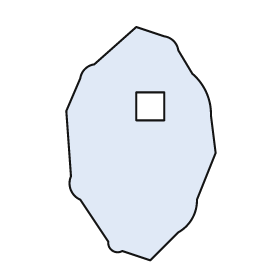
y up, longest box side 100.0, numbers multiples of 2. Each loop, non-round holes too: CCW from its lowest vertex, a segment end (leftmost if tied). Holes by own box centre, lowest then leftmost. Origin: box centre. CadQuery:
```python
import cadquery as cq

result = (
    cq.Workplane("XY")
    .moveTo(4.0, -50.0)
    .lineTo(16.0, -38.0)
    .threePointArc((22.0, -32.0), (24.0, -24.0))
    .lineTo(32.0, -4.0)
    .lineTo(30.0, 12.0)
    .threePointArc((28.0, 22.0), (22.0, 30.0))
    .lineTo(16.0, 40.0)
    .threePointArc((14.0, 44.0), (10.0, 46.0))
    .lineTo(-2.0, 50.0)
    .lineTo(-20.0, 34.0)
    .threePointArc((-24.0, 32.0), (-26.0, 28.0))
    .lineTo(-32.0, 14.0)
    .lineTo(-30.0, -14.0)
    .threePointArc((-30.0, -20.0), (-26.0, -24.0))
    .lineTo(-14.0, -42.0)
    .threePointArc((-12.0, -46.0), (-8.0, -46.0))
    .close()
    .moveTo(-2.0, 10.0)
    .lineTo(10.0, 10.0)
    .lineTo(10.0, 22.0)
    .lineTo(-2.0, 22.0)
    .close()
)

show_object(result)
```